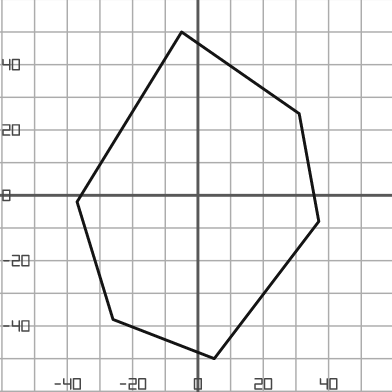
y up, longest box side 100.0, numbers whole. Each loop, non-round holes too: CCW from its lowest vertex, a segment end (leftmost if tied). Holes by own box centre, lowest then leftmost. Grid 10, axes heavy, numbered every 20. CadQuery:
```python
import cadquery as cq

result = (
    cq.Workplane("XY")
    .moveTo(5.0, -50.0)
    .lineTo(37.0, -8.0)
    .lineTo(31.0, 25.0)
    .lineTo(-5.0, 50.0)
    .lineTo(-37.0, -2.0)
    .lineTo(-26.0, -38.0)
    .close()
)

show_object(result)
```